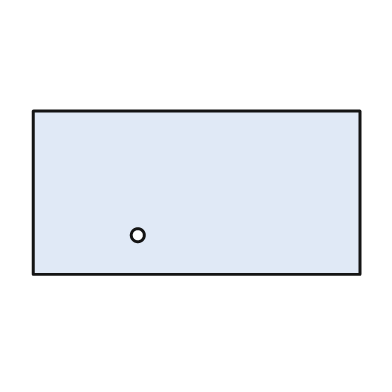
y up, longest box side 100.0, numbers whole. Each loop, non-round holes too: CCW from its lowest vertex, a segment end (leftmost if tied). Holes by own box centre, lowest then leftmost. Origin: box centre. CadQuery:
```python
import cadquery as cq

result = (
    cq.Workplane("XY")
    .moveTo(-50.0, -25.0)
    .lineTo(50.0, -25.0)
    .lineTo(50.0, 25.0)
    .lineTo(-50.0, 25.0)
    .close()
    .moveTo(-18.0, -13.0)
    .circle(2.0)
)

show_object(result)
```